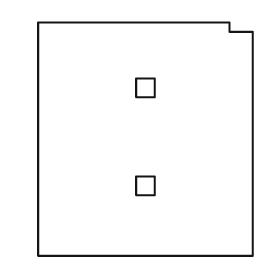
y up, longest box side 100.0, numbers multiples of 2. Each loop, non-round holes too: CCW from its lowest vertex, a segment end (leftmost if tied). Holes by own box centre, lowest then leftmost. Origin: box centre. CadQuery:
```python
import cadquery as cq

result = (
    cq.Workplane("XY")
    .moveTo(-46.0, -50.0)
    .lineTo(46.0, -50.0)
    .lineTo(46.0, 46.0)
    .lineTo(36.0, 46.0)
    .lineTo(36.0, 50.0)
    .lineTo(-46.0, 50.0)
    .close()
    .moveTo(-4.0, -24.0)
    .lineTo(4.0, -24.0)
    .lineTo(4.0, -16.0)
    .lineTo(-4.0, -16.0)
    .close()
    .moveTo(-4.0, 18.0)
    .lineTo(4.0, 18.0)
    .lineTo(4.0, 26.0)
    .lineTo(-4.0, 26.0)
    .close()
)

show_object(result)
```